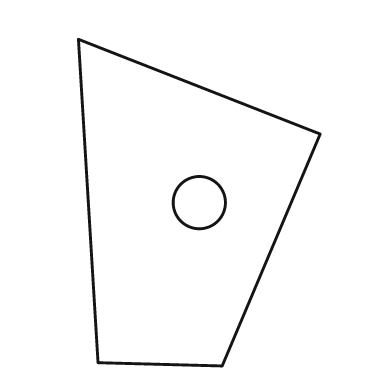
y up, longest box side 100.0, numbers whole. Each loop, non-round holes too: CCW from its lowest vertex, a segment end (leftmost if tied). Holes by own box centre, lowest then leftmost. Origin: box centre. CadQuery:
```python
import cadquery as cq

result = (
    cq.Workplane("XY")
    .moveTo(7.0, -50.0)
    .lineTo(37.0, 21.0)
    .lineTo(-37.0, 50.0)
    .lineTo(-31.0, -49.0)
    .close()
    .moveTo(0.0, 0.0)
    .circle(8.0)
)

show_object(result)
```